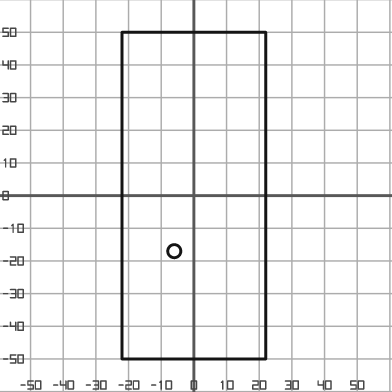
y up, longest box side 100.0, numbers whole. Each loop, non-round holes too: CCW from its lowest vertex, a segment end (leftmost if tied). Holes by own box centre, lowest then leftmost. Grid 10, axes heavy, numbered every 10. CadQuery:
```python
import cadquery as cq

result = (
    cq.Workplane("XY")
    .moveTo(-22.0, -50.0)
    .lineTo(22.0, -50.0)
    .lineTo(22.0, 50.0)
    .lineTo(-22.0, 50.0)
    .close()
    .moveTo(-6.0, -17.0)
    .circle(2.0)
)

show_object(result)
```